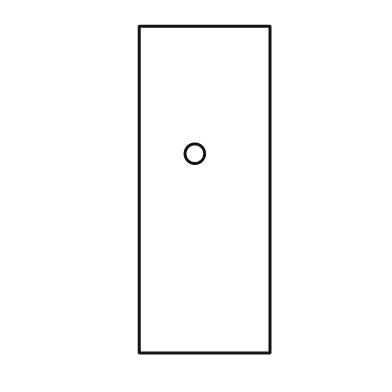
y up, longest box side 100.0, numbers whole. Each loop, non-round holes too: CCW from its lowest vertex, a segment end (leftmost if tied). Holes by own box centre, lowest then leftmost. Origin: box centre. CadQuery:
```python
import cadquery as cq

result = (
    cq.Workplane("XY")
    .moveTo(-20.0, -50.0)
    .lineTo(20.0, -50.0)
    .lineTo(20.0, 50.0)
    .lineTo(-20.0, 50.0)
    .close()
    .moveTo(-3.0, 11.0)
    .circle(3.0)
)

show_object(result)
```